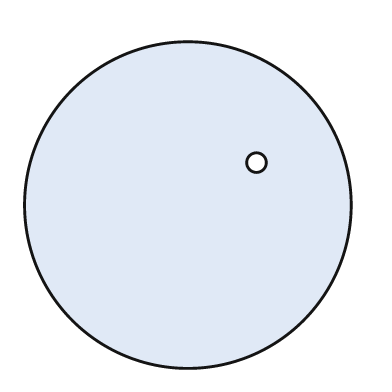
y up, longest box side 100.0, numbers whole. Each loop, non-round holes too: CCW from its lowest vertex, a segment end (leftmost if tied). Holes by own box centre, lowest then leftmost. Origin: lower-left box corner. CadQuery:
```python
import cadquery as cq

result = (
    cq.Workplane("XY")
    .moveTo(50.0, 50.0)
    .circle(50.0)
    .moveTo(71.0, 63.0)
    .circle(3.0)
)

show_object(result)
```